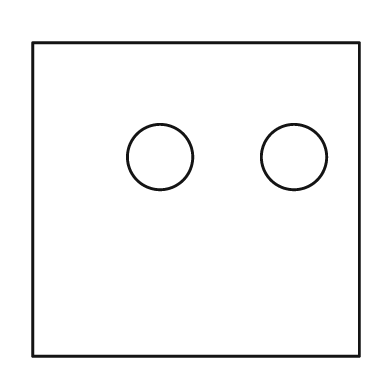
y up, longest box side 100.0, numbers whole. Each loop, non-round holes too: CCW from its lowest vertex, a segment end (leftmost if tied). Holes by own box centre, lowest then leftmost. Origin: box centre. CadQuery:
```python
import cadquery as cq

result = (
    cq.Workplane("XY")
    .moveTo(-50.0, -48.0)
    .lineTo(50.0, -48.0)
    .lineTo(50.0, 48.0)
    .lineTo(-50.0, 48.0)
    .close()
    .moveTo(-11.0, 13.0)
    .circle(10.0)
    .moveTo(30.0, 13.0)
    .circle(10.0)
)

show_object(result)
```